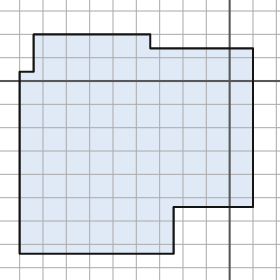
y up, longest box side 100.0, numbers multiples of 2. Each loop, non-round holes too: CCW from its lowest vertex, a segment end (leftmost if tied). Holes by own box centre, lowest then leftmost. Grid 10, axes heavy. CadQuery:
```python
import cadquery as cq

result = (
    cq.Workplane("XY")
    .moveTo(-90.0, -74.0)
    .lineTo(-24.0, -74.0)
    .lineTo(-24.0, -54.0)
    .lineTo(10.0, -54.0)
    .lineTo(10.0, 14.0)
    .lineTo(-34.0, 14.0)
    .lineTo(-34.0, 20.0)
    .lineTo(-84.0, 20.0)
    .lineTo(-84.0, 4.0)
    .lineTo(-90.0, 4.0)
    .close()
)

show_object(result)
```